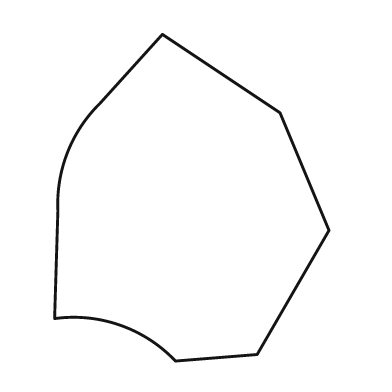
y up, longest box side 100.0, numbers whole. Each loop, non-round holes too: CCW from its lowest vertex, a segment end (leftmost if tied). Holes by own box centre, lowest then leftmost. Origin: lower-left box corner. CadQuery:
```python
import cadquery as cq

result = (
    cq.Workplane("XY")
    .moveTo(37.0, 0.0)
    .lineTo(62.0, 2.0)
    .lineTo(84.0, 40.0)
    .lineTo(69.0, 76.0)
    .lineTo(33.0, 100.0)
    .lineTo(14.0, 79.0)
    .threePointArc((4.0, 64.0), (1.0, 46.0))
    .lineTo(0.0, 13.0)
    .threePointArc((20.0, 11.0), (37.0, 0.0))
    .close()
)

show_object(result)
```